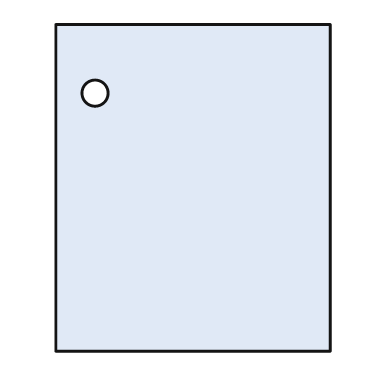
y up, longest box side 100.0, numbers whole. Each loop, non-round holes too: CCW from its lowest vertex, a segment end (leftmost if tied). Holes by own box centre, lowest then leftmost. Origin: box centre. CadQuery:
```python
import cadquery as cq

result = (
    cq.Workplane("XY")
    .moveTo(-42.0, -50.0)
    .lineTo(42.0, -50.0)
    .lineTo(42.0, 50.0)
    .lineTo(-42.0, 50.0)
    .close()
    .moveTo(-30.0, 29.0)
    .circle(4.0)
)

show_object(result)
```